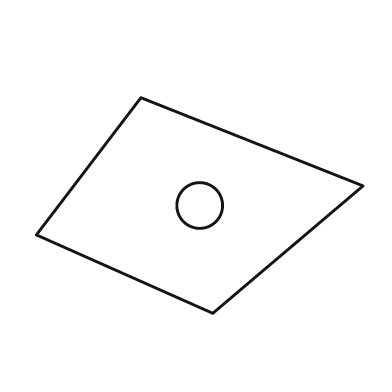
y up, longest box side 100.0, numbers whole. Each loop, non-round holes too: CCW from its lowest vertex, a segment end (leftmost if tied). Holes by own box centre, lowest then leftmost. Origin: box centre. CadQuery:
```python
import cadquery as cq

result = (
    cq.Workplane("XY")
    .moveTo(4.0, -33.0)
    .lineTo(50.0, 6.0)
    .lineTo(-18.0, 33.0)
    .lineTo(-50.0, -9.0)
    .close()
    .moveTo(0.0, 0.0)
    .circle(7.0)
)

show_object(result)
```